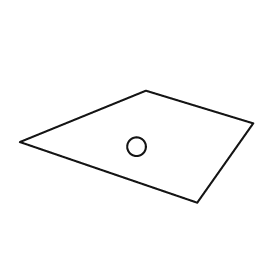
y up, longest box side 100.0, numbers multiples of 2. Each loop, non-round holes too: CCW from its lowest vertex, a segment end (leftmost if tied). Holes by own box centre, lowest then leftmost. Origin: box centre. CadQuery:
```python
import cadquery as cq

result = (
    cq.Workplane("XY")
    .moveTo(26.0, -24.0)
    .lineTo(50.0, 10.0)
    .lineTo(4.0, 24.0)
    .lineTo(-50.0, 2.0)
    .close()
    .moveTo(0.0, 0.0)
    .circle(4.0)
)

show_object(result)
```